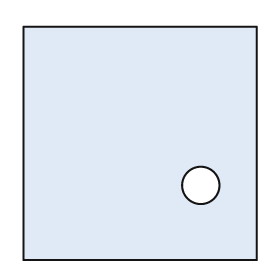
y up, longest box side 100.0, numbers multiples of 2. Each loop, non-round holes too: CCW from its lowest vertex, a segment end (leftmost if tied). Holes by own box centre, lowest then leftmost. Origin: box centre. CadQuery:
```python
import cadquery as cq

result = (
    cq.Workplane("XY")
    .moveTo(-50.0, -50.0)
    .lineTo(50.0, -50.0)
    .lineTo(50.0, 50.0)
    .lineTo(-50.0, 50.0)
    .close()
    .moveTo(26.0, -18.0)
    .circle(8.0)
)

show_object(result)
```